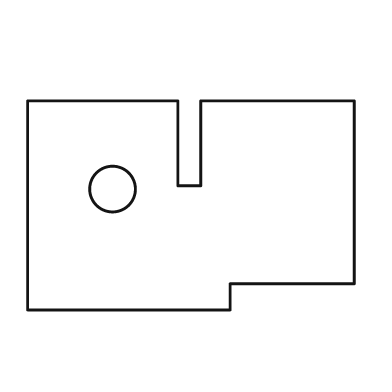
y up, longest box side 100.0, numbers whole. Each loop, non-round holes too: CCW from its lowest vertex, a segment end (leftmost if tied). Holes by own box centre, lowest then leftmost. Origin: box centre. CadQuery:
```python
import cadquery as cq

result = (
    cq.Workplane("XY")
    .moveTo(-50.0, -32.0)
    .lineTo(12.0, -32.0)
    .lineTo(12.0, -24.0)
    .lineTo(50.0, -24.0)
    .lineTo(50.0, 32.0)
    .lineTo(3.0, 32.0)
    .lineTo(3.0, 6.0)
    .lineTo(-4.0, 6.0)
    .lineTo(-4.0, 32.0)
    .lineTo(-50.0, 32.0)
    .close()
    .moveTo(-24.0, 5.0)
    .circle(7.0)
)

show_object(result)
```